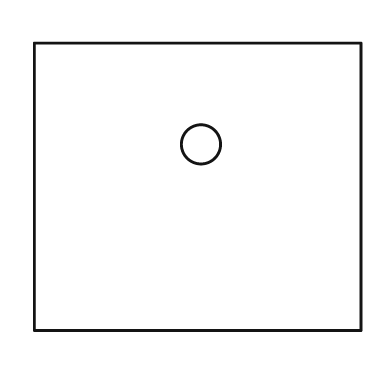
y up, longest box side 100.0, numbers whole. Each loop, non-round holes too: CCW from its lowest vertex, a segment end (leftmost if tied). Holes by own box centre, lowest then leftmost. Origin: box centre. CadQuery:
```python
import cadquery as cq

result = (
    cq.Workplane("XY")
    .moveTo(-50.0, -44.0)
    .lineTo(50.0, -44.0)
    .lineTo(50.0, 44.0)
    .lineTo(-50.0, 44.0)
    .close()
    .moveTo(1.0, 13.0)
    .circle(6.0)
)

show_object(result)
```